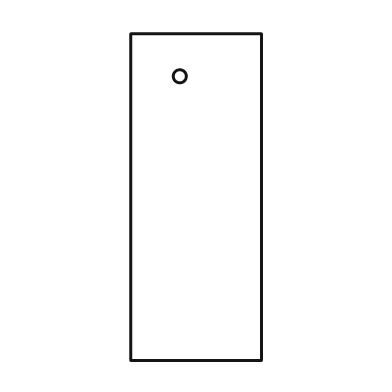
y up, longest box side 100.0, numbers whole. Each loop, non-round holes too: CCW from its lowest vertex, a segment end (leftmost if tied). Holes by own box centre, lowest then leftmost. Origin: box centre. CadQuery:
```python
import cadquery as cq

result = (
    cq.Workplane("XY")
    .moveTo(-20.0, -50.0)
    .lineTo(20.0, -50.0)
    .lineTo(20.0, 50.0)
    .lineTo(-20.0, 50.0)
    .close()
    .moveTo(-5.0, 37.0)
    .circle(2.0)
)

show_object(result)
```